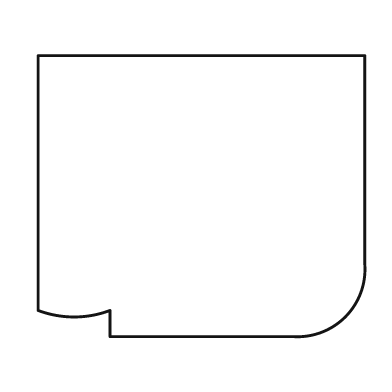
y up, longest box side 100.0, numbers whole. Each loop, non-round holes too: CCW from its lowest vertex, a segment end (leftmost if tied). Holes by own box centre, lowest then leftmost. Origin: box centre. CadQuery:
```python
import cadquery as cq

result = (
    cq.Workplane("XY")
    .moveTo(-28.0, -43.0)
    .lineTo(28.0, -43.0)
    .threePointArc((44.0, -37.0), (50.0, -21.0))
    .lineTo(50.0, 43.0)
    .lineTo(-50.0, 43.0)
    .lineTo(-50.0, -35.0)
    .threePointArc((-39.0, -37.0), (-28.0, -35.0))
    .close()
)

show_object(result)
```